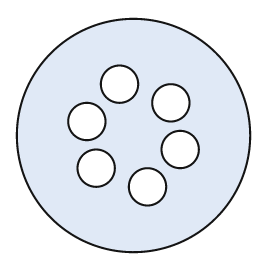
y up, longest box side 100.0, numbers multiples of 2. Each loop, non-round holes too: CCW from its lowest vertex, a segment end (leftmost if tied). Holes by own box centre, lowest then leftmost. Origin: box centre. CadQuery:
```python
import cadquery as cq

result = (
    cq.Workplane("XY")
    .moveTo(0.0, 0.0)
    .circle(50.0)
    .moveTo(6.0, -22.0)
    .circle(8.0)
    .moveTo(-16.0, -14.0)
    .circle(8.0)
    .moveTo(20.0, -6.0)
    .circle(8.0)
    .moveTo(-20.0, 6.0)
    .circle(8.0)
    .moveTo(16.0, 14.0)
    .circle(8.0)
    .moveTo(-6.0, 22.0)
    .circle(8.0)
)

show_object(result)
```